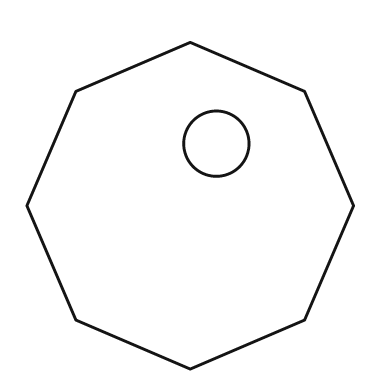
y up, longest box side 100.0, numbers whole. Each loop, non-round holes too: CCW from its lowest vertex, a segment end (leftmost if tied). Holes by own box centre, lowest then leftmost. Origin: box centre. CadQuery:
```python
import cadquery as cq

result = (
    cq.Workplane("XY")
    .moveTo(0.0, -50.0)
    .lineTo(35.0, -35.0)
    .lineTo(50.0, 0.0)
    .lineTo(35.0, 35.0)
    .lineTo(0.0, 50.0)
    .lineTo(-35.0, 35.0)
    .lineTo(-50.0, 0.0)
    .lineTo(-35.0, -35.0)
    .close()
    .moveTo(8.0, 19.0)
    .circle(10.0)
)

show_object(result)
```